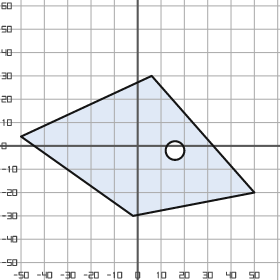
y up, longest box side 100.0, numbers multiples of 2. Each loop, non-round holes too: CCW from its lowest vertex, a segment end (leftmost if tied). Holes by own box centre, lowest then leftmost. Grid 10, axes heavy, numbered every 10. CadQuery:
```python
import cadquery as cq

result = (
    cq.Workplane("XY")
    .moveTo(-2.0, -30.0)
    .lineTo(50.0, -20.0)
    .lineTo(6.0, 30.0)
    .lineTo(-50.0, 4.0)
    .close()
    .moveTo(16.0, -2.0)
    .circle(4.0)
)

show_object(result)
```